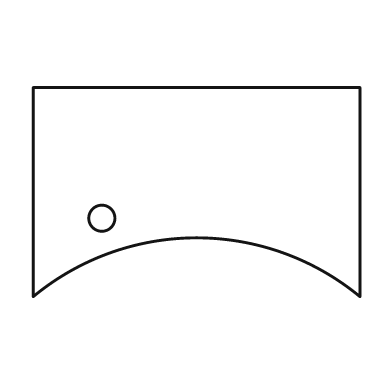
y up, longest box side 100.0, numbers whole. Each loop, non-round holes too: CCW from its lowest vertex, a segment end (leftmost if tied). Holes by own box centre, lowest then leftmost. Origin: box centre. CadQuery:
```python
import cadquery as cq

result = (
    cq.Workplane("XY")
    .moveTo(-50.0, -32.0)
    .threePointArc((0.0, -14.0), (50.0, -32.0))
    .lineTo(50.0, 32.0)
    .lineTo(-50.0, 32.0)
    .close()
    .moveTo(-29.0, -8.0)
    .circle(4.0)
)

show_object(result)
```